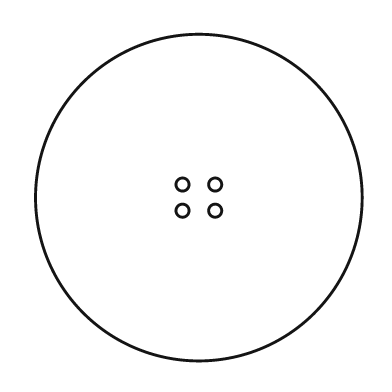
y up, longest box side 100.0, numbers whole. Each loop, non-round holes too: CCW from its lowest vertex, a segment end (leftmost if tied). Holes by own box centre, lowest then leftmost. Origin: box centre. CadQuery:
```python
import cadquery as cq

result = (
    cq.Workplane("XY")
    .moveTo(0.0, 0.0)
    .circle(50.0)
    .moveTo(-5.0, -4.0)
    .circle(2.0)
    .moveTo(5.0, -4.0)
    .circle(2.0)
    .moveTo(-5.0, 4.0)
    .circle(2.0)
    .moveTo(5.0, 4.0)
    .circle(2.0)
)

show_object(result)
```